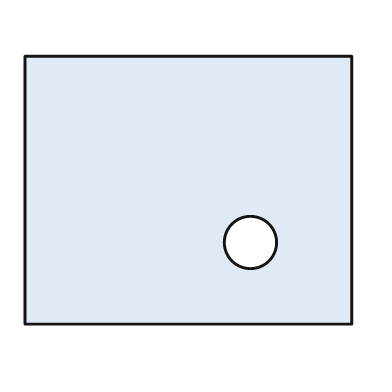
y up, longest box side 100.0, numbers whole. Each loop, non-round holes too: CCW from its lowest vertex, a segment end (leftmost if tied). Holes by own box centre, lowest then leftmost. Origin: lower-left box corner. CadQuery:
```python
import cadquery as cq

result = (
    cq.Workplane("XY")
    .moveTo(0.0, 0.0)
    .lineTo(100.0, 0.0)
    .lineTo(100.0, 82.0)
    .lineTo(0.0, 82.0)
    .close()
    .moveTo(69.0, 25.0)
    .circle(8.0)
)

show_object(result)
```